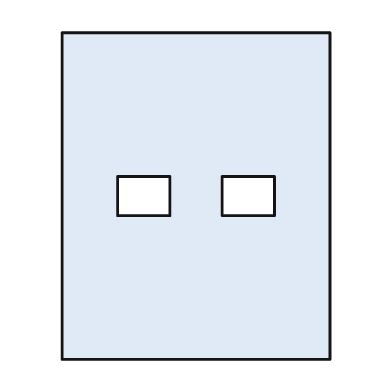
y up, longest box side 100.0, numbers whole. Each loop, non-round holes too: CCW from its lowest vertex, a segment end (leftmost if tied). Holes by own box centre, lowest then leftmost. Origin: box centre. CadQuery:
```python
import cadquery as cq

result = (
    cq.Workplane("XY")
    .moveTo(-41.0, -50.0)
    .lineTo(41.0, -50.0)
    .lineTo(41.0, 50.0)
    .lineTo(-41.0, 50.0)
    .close()
    .moveTo(-24.0, -6.0)
    .lineTo(-8.0, -6.0)
    .lineTo(-8.0, 6.0)
    .lineTo(-24.0, 6.0)
    .close()
    .moveTo(8.0, -6.0)
    .lineTo(24.0, -6.0)
    .lineTo(24.0, 6.0)
    .lineTo(8.0, 6.0)
    .close()
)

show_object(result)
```